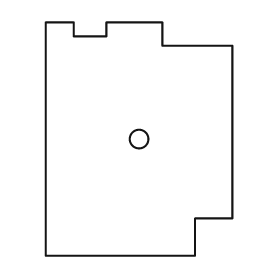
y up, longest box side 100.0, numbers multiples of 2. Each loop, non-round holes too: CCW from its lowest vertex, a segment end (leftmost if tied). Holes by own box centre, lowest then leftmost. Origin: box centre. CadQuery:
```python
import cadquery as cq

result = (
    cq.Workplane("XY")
    .moveTo(-40.0, -50.0)
    .lineTo(24.0, -50.0)
    .lineTo(24.0, -34.0)
    .lineTo(40.0, -34.0)
    .lineTo(40.0, 40.0)
    .lineTo(10.0, 40.0)
    .lineTo(10.0, 50.0)
    .lineTo(-14.0, 50.0)
    .lineTo(-14.0, 44.0)
    .lineTo(-28.0, 44.0)
    .lineTo(-28.0, 50.0)
    .lineTo(-40.0, 50.0)
    .close()
    .moveTo(0.0, 0.0)
    .circle(4.0)
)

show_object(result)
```